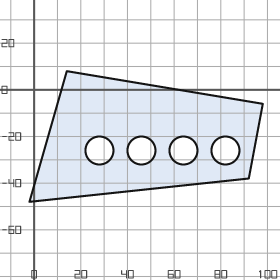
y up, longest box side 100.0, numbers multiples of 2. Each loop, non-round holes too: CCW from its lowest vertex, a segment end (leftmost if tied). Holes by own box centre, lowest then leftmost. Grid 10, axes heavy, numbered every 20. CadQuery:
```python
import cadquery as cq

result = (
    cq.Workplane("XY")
    .moveTo(-2.0, -48.0)
    .lineTo(92.0, -38.0)
    .lineTo(98.0, -6.0)
    .lineTo(14.0, 8.0)
    .close()
    .moveTo(28.0, -26.0)
    .circle(6.0)
    .moveTo(46.0, -26.0)
    .circle(6.0)
    .moveTo(64.0, -26.0)
    .circle(6.0)
    .moveTo(82.0, -26.0)
    .circle(6.0)
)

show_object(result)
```